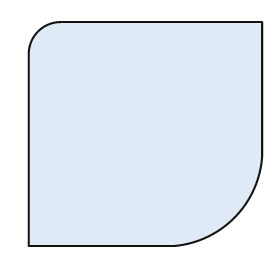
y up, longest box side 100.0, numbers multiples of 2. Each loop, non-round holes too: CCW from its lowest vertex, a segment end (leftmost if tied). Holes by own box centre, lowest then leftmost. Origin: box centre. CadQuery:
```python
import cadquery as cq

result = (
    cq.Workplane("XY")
    .moveTo(-50.0, -48.0)
    .lineTo(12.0, -48.0)
    .threePointArc((38.0, -36.0), (50.0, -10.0))
    .lineTo(50.0, 48.0)
    .lineTo(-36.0, 48.0)
    .threePointArc((-46.0, 44.0), (-50.0, 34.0))
    .close()
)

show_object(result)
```